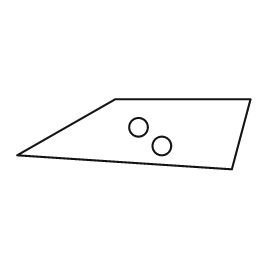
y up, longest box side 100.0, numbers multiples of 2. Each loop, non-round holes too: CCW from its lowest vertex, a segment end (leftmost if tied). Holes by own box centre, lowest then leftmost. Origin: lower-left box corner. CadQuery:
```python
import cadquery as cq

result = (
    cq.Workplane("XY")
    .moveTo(92.0, 0.0)
    .lineTo(100.0, 30.0)
    .lineTo(42.0, 30.0)
    .lineTo(0.0, 6.0)
    .close()
    .moveTo(62.0, 10.0)
    .circle(4.0)
    .moveTo(52.0, 18.0)
    .circle(4.0)
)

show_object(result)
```